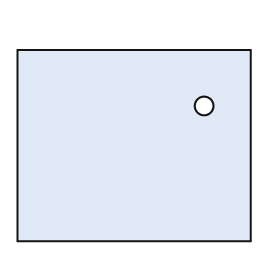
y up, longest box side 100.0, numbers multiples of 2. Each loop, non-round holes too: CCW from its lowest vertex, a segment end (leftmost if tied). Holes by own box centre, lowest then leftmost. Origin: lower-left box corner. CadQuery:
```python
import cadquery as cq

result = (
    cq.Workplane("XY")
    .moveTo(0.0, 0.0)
    .lineTo(100.0, 0.0)
    .lineTo(100.0, 82.0)
    .lineTo(0.0, 82.0)
    .close()
    .moveTo(80.0, 58.0)
    .circle(4.0)
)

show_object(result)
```